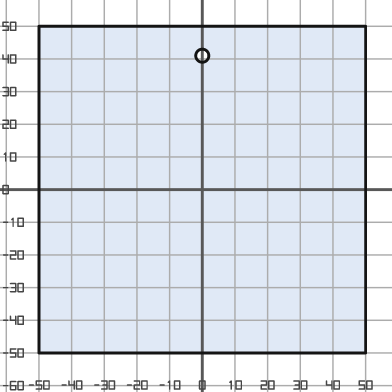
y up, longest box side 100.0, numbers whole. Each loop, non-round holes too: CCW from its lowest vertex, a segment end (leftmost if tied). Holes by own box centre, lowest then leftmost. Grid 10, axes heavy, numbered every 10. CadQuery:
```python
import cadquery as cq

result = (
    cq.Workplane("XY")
    .moveTo(-50.0, -50.0)
    .lineTo(50.0, -50.0)
    .lineTo(50.0, 50.0)
    .lineTo(-50.0, 50.0)
    .close()
    .moveTo(0.0, 41.0)
    .circle(2.0)
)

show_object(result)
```